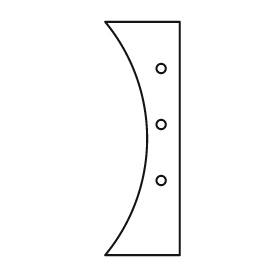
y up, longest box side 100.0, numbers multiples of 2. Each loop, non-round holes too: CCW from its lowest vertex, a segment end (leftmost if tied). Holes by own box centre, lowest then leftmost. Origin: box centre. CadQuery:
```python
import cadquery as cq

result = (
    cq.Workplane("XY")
    .moveTo(-16.0, -50.0)
    .lineTo(16.0, -50.0)
    .lineTo(16.0, 50.0)
    .lineTo(-16.0, 50.0)
    .threePointArc((2.0, 0.0), (-16.0, -50.0))
    .close()
    .moveTo(8.0, -18.0)
    .circle(2.0)
    .moveTo(8.0, 6.0)
    .circle(2.0)
    .moveTo(8.0, 30.0)
    .circle(2.0)
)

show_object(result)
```